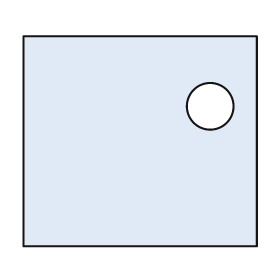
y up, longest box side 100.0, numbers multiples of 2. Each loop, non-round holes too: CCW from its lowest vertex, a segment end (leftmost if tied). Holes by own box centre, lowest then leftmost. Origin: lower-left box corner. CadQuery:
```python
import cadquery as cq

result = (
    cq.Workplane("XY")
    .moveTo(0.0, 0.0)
    .lineTo(100.0, 0.0)
    .lineTo(100.0, 90.0)
    .lineTo(0.0, 90.0)
    .close()
    .moveTo(80.0, 60.0)
    .circle(10.0)
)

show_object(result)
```